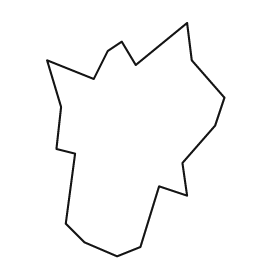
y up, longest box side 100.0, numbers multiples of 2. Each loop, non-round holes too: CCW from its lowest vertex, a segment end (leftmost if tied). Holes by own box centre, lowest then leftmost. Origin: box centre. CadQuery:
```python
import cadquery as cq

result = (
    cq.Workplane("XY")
    .moveTo(-8.0, -50.0)
    .lineTo(2.0, -46.0)
    .lineTo(10.0, -20.0)
    .lineTo(22.0, -24.0)
    .lineTo(20.0, -10.0)
    .lineTo(34.0, 6.0)
    .lineTo(38.0, 18.0)
    .lineTo(24.0, 34.0)
    .lineTo(22.0, 50.0)
    .lineTo(0.0, 32.0)
    .lineTo(-6.0, 42.0)
    .lineTo(-12.0, 38.0)
    .lineTo(-18.0, 26.0)
    .lineTo(-38.0, 34.0)
    .lineTo(-32.0, 14.0)
    .lineTo(-34.0, -4.0)
    .lineTo(-26.0, -6.0)
    .lineTo(-30.0, -36.0)
    .lineTo(-22.0, -44.0)
    .close()
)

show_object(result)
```